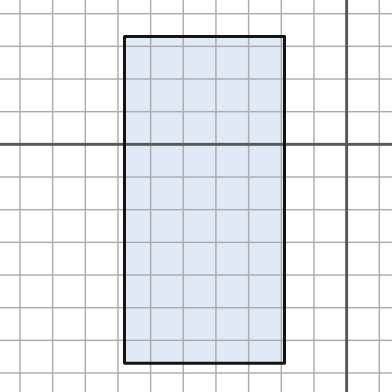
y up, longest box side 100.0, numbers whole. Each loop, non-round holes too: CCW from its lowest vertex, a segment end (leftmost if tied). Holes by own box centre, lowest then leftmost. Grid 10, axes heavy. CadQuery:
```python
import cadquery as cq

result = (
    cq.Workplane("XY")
    .moveTo(-68.0, -67.0)
    .lineTo(-19.0, -67.0)
    .lineTo(-19.0, 33.0)
    .lineTo(-68.0, 33.0)
    .close()
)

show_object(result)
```